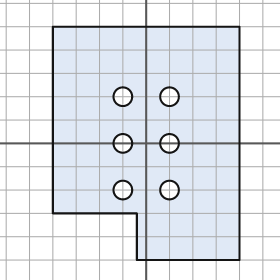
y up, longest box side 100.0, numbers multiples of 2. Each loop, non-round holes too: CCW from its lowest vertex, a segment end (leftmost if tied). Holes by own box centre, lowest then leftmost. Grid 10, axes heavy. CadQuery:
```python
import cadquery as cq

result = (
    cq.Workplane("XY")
    .moveTo(-4.0, -50.0)
    .lineTo(40.0, -50.0)
    .lineTo(40.0, 50.0)
    .lineTo(-40.0, 50.0)
    .lineTo(-40.0, -30.0)
    .lineTo(-4.0, -30.0)
    .close()
    .moveTo(-10.0, -20.0)
    .circle(4.0)
    .moveTo(10.0, -20.0)
    .circle(4.0)
    .moveTo(-10.0, 0.0)
    .circle(4.0)
    .moveTo(10.0, 0.0)
    .circle(4.0)
    .moveTo(-10.0, 20.0)
    .circle(4.0)
    .moveTo(10.0, 20.0)
    .circle(4.0)
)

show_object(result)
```